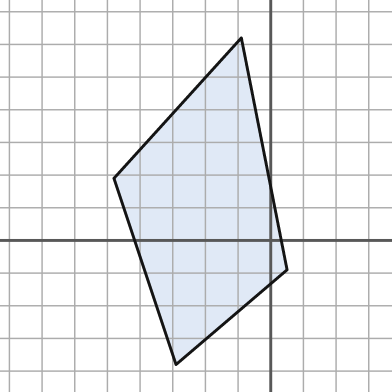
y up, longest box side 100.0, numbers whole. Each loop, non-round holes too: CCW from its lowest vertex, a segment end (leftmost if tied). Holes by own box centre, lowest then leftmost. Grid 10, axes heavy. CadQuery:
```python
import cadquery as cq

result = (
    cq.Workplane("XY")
    .moveTo(-29.0, -38.0)
    .lineTo(5.0, -9.0)
    .lineTo(-9.0, 62.0)
    .lineTo(-48.0, 19.0)
    .close()
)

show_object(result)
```